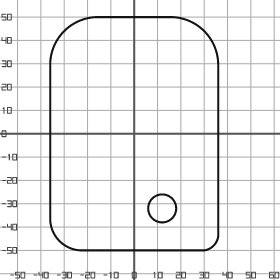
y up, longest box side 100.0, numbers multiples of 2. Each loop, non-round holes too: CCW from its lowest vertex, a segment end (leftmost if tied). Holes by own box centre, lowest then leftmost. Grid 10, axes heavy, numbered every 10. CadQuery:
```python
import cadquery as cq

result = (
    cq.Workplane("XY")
    .moveTo(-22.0, -50.0)
    .lineTo(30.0, -50.0)
    .threePointArc((34.0, -48.0), (36.0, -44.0))
    .lineTo(36.0, 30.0)
    .threePointArc((30.0, 44.0), (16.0, 50.0))
    .lineTo(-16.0, 50.0)
    .threePointArc((-30.0, 44.0), (-36.0, 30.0))
    .lineTo(-36.0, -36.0)
    .threePointArc((-32.0, -46.0), (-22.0, -50.0))
    .close()
    .moveTo(12.0, -32.0)
    .circle(6.0)
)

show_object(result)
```